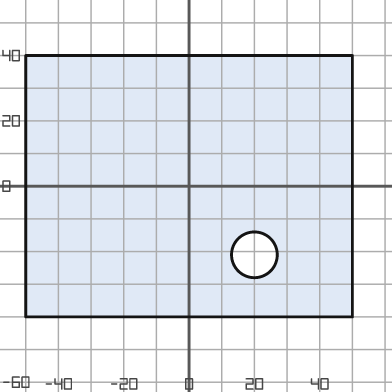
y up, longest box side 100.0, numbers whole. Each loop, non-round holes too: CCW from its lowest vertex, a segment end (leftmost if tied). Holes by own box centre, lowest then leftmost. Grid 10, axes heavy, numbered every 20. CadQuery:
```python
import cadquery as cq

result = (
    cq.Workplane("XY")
    .moveTo(-50.0, -40.0)
    .lineTo(50.0, -40.0)
    .lineTo(50.0, 40.0)
    .lineTo(-50.0, 40.0)
    .close()
    .moveTo(20.0, -21.0)
    .circle(7.0)
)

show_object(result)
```